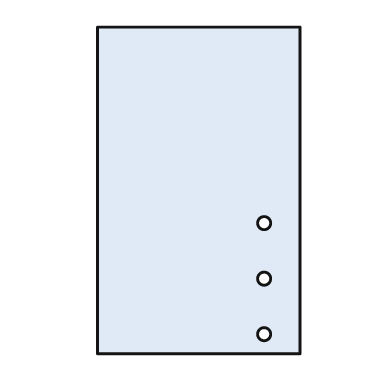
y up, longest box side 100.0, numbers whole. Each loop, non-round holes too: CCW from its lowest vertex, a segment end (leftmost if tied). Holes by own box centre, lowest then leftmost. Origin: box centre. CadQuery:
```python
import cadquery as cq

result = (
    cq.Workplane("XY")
    .moveTo(-31.0, -50.0)
    .lineTo(31.0, -50.0)
    .lineTo(31.0, 50.0)
    .lineTo(-31.0, 50.0)
    .close()
    .moveTo(20.0, -44.0)
    .circle(2.0)
    .moveTo(20.0, -27.0)
    .circle(2.0)
    .moveTo(20.0, -10.0)
    .circle(2.0)
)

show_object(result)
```